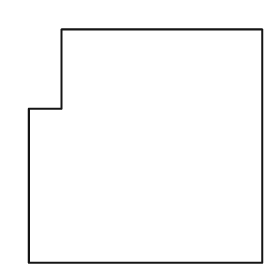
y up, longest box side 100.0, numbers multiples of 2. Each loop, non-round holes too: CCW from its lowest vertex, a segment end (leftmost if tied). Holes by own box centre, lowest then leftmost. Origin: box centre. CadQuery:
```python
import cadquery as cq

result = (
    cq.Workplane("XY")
    .moveTo(-50.0, -50.0)
    .lineTo(50.0, -50.0)
    .lineTo(50.0, 50.0)
    .lineTo(-36.0, 50.0)
    .lineTo(-36.0, 16.0)
    .lineTo(-50.0, 16.0)
    .close()
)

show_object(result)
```